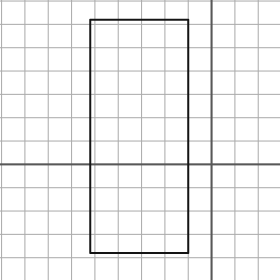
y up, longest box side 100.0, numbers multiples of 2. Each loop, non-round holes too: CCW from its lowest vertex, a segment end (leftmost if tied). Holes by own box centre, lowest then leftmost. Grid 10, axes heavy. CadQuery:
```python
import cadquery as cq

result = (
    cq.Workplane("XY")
    .moveTo(-52.0, -38.0)
    .lineTo(-10.0, -38.0)
    .lineTo(-10.0, 62.0)
    .lineTo(-52.0, 62.0)
    .close()
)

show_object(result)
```